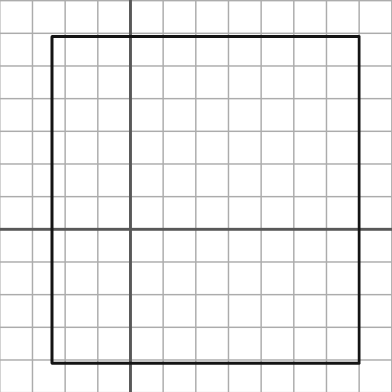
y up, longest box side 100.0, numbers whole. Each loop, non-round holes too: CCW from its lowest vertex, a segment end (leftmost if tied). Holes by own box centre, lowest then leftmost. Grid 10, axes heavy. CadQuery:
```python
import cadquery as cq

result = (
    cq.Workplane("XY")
    .moveTo(-24.0, -41.0)
    .lineTo(70.0, -41.0)
    .lineTo(70.0, 59.0)
    .lineTo(-24.0, 59.0)
    .close()
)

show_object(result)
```